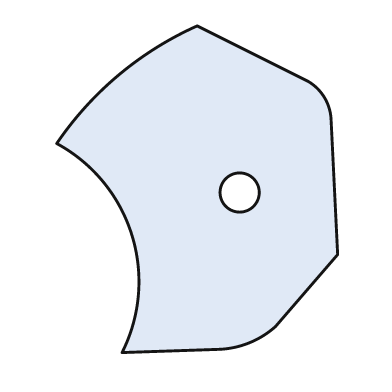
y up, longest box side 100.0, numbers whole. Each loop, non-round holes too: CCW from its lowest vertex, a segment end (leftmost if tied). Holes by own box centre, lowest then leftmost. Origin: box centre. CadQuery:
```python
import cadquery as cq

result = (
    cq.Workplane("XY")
    .moveTo(-23.0, -50.0)
    .lineTo(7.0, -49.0)
    .threePointArc((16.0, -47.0), (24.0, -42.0))
    .lineTo(43.0, -20.0)
    .lineTo(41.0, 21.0)
    .threePointArc((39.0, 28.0), (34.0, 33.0))
    .lineTo(0.0, 50.0)
    .threePointArc((-24.0, 35.0), (-43.0, 14.0))
    .threePointArc((-20.0, -14.0), (-23.0, -50.0))
    .close()
    .moveTo(13.0, -1.0)
    .circle(6.0)
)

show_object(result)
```